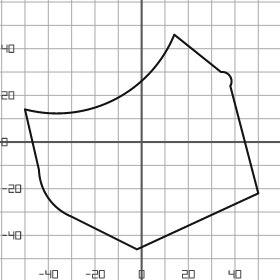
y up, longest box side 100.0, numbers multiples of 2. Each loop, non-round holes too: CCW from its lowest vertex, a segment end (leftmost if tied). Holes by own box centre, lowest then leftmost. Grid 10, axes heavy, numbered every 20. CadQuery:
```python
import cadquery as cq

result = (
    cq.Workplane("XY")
    .moveTo(-2.0, -46.0)
    .lineTo(50.0, -22.0)
    .lineTo(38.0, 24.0)
    .threePointArc((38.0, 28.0), (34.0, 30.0))
    .lineTo(14.0, 46.0)
    .threePointArc((-12.0, 18.0), (-50.0, 14.0))
    .lineTo(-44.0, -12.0)
    .threePointArc((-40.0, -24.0), (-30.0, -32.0))
    .close()
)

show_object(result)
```